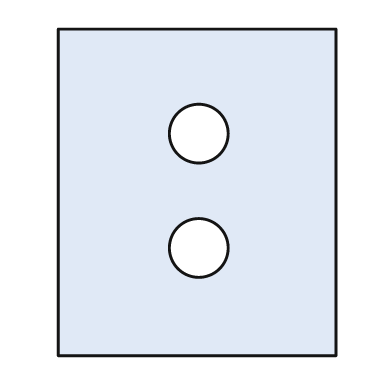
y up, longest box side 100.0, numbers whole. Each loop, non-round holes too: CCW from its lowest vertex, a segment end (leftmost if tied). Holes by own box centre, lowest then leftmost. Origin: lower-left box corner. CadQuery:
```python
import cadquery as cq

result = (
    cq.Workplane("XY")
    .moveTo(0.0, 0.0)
    .lineTo(85.0, 0.0)
    .lineTo(85.0, 100.0)
    .lineTo(0.0, 100.0)
    .close()
    .moveTo(43.0, 33.0)
    .circle(9.0)
    .moveTo(43.0, 68.0)
    .circle(9.0)
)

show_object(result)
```